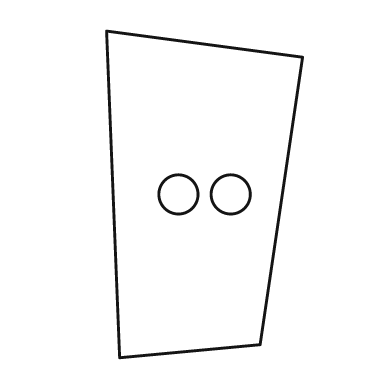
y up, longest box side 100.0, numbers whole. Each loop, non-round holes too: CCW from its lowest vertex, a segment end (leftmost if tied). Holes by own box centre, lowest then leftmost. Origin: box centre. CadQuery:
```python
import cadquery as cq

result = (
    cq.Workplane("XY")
    .moveTo(-26.0, -50.0)
    .lineTo(17.0, -46.0)
    .lineTo(30.0, 42.0)
    .lineTo(-30.0, 50.0)
    .close()
    .moveTo(-8.0, 0.0)
    .circle(6.0)
    .moveTo(8.0, 0.0)
    .circle(6.0)
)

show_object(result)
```